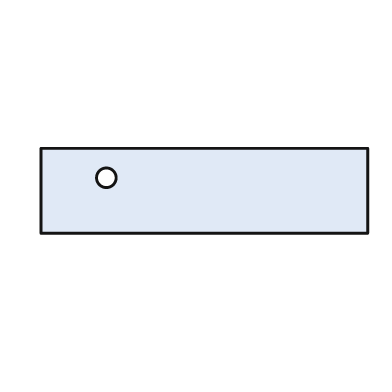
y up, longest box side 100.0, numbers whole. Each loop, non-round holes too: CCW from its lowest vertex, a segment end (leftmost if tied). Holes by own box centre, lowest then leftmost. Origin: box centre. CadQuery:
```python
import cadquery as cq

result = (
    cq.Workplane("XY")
    .moveTo(-50.0, -13.0)
    .lineTo(50.0, -13.0)
    .lineTo(50.0, 13.0)
    .lineTo(-50.0, 13.0)
    .close()
    .moveTo(-30.0, 4.0)
    .circle(3.0)
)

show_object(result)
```